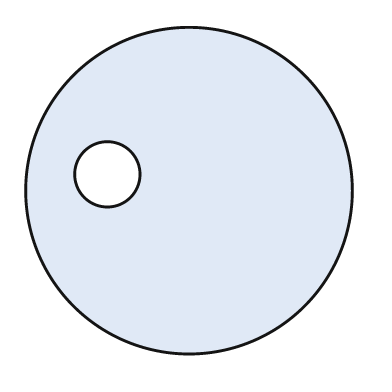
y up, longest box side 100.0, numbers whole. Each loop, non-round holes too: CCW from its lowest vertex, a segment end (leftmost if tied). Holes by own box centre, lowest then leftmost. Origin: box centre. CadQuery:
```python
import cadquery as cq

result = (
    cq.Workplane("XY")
    .moveTo(0.0, 0.0)
    .circle(50.0)
    .moveTo(-25.0, 5.0)
    .circle(10.0)
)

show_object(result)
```